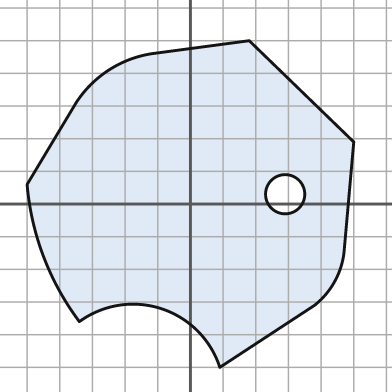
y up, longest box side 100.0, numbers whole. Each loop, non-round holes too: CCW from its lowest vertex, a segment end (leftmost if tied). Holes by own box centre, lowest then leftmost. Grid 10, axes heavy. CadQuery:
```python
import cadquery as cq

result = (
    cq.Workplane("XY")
    .moveTo(9.0, -50.0)
    .lineTo(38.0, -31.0)
    .threePointArc((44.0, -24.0), (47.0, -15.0))
    .lineTo(50.0, 19.0)
    .lineTo(18.0, 50.0)
    .lineTo(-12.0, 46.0)
    .threePointArc((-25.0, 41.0), (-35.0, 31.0))
    .lineTo(-50.0, 6.0)
    .threePointArc((-45.0, -16.0), (-34.0, -36.0))
    .threePointArc((-9.0, -32.0), (9.0, -50.0))
    .close()
    .moveTo(29.0, 3.0)
    .circle(6.0)
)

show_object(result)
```